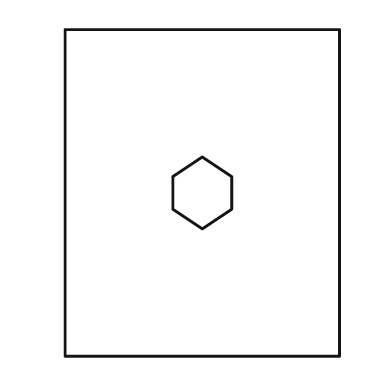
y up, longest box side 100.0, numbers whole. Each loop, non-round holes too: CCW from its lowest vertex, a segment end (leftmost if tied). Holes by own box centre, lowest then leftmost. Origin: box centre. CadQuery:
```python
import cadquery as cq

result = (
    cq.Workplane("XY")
    .moveTo(-42.0, -50.0)
    .lineTo(42.0, -50.0)
    .lineTo(42.0, 50.0)
    .lineTo(-42.0, 50.0)
    .close()
    .moveTo(0.0, -11.0)
    .lineTo(9.0, -5.0)
    .lineTo(9.0, 5.0)
    .lineTo(0.0, 11.0)
    .lineTo(-9.0, 5.0)
    .lineTo(-9.0, -5.0)
    .close()
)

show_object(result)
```